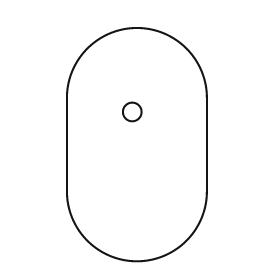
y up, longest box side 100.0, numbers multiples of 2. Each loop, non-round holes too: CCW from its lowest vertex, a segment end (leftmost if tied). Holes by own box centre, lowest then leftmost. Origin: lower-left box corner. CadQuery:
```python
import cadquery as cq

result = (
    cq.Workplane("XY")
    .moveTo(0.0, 30.0)
    .threePointArc((30.0, 0.0), (60.0, 30.0))
    .lineTo(60.0, 70.0)
    .threePointArc((30.0, 100.0), (0.0, 70.0))
    .close()
    .moveTo(28.0, 64.0)
    .circle(4.0)
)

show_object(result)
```